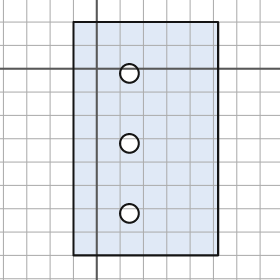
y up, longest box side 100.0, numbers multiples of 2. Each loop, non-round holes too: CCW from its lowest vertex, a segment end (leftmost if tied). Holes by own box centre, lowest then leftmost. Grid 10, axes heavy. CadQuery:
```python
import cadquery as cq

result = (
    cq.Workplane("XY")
    .moveTo(-10.0, -80.0)
    .lineTo(52.0, -80.0)
    .lineTo(52.0, 20.0)
    .lineTo(-10.0, 20.0)
    .close()
    .moveTo(14.0, -62.0)
    .circle(4.0)
    .moveTo(14.0, -32.0)
    .circle(4.0)
    .moveTo(14.0, -2.0)
    .circle(4.0)
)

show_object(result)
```